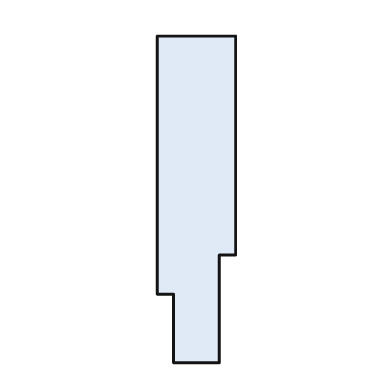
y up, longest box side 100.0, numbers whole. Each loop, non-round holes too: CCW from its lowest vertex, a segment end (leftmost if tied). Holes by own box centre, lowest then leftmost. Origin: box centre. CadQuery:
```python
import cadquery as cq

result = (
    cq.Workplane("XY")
    .moveTo(-7.0, -50.0)
    .lineTo(7.0, -50.0)
    .lineTo(7.0, -17.0)
    .lineTo(12.0, -17.0)
    .lineTo(12.0, 50.0)
    .lineTo(-12.0, 50.0)
    .lineTo(-12.0, -29.0)
    .lineTo(-7.0, -29.0)
    .close()
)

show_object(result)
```